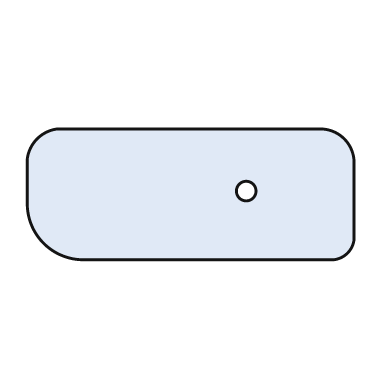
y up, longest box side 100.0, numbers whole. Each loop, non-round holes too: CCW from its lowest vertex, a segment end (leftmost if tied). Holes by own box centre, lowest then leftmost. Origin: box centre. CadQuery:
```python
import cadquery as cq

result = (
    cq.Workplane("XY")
    .moveTo(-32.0, -20.0)
    .lineTo(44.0, -20.0)
    .threePointArc((48.0, -18.0), (50.0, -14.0))
    .lineTo(50.0, 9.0)
    .threePointArc((47.0, 17.0), (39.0, 20.0))
    .lineTo(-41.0, 20.0)
    .threePointArc((-47.0, 17.0), (-50.0, 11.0))
    .lineTo(-50.0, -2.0)
    .threePointArc((-45.0, -15.0), (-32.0, -20.0))
    .close()
    .moveTo(17.0, 1.0)
    .circle(3.0)
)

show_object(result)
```